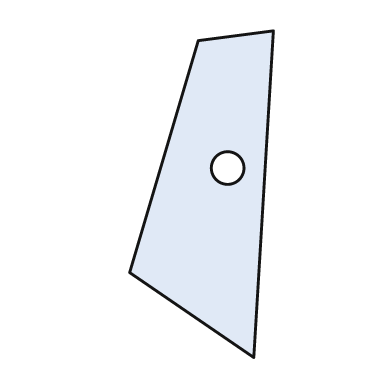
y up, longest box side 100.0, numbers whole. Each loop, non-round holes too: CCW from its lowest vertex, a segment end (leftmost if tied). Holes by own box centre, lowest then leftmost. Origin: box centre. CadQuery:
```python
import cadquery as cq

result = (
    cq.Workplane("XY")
    .moveTo(16.0, -50.0)
    .lineTo(22.0, 50.0)
    .lineTo(-1.0, 47.0)
    .lineTo(-22.0, -24.0)
    .close()
    .moveTo(8.0, 8.0)
    .circle(5.0)
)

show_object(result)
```